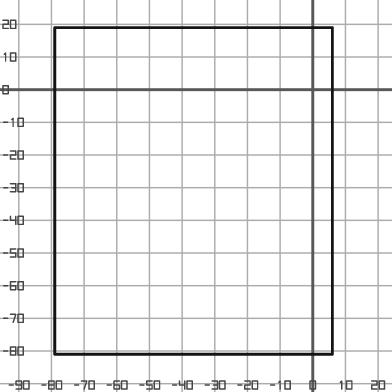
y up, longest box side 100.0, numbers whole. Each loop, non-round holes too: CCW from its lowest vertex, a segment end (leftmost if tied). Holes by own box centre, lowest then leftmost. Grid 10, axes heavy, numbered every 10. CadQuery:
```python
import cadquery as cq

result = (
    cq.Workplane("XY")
    .moveTo(-79.0, -81.0)
    .lineTo(6.0, -81.0)
    .lineTo(6.0, 19.0)
    .lineTo(-79.0, 19.0)
    .close()
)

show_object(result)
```